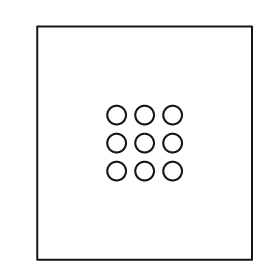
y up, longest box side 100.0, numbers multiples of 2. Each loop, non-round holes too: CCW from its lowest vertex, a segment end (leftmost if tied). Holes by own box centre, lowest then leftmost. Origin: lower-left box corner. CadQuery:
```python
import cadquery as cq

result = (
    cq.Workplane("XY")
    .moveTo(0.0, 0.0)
    .lineTo(92.0, 0.0)
    .lineTo(92.0, 100.0)
    .lineTo(0.0, 100.0)
    .close()
    .moveTo(34.0, 38.0)
    .circle(4.0)
    .moveTo(46.0, 38.0)
    .circle(4.0)
    .moveTo(58.0, 38.0)
    .circle(4.0)
    .moveTo(34.0, 50.0)
    .circle(4.0)
    .moveTo(46.0, 50.0)
    .circle(4.0)
    .moveTo(58.0, 50.0)
    .circle(4.0)
    .moveTo(34.0, 62.0)
    .circle(4.0)
    .moveTo(46.0, 62.0)
    .circle(4.0)
    .moveTo(58.0, 62.0)
    .circle(4.0)
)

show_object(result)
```